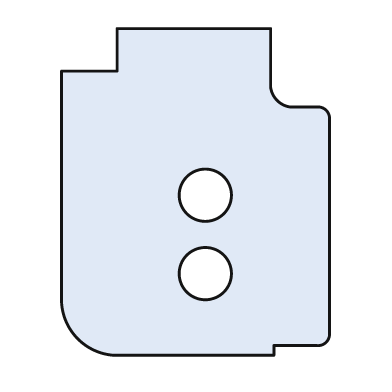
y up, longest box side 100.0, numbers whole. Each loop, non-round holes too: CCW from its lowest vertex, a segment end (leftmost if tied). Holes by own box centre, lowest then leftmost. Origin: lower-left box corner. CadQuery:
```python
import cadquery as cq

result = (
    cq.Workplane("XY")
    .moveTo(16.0, 0.0)
    .lineTo(65.0, 0.0)
    .lineTo(65.0, 3.0)
    .lineTo(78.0, 3.0)
    .threePointArc((81.0, 4.0), (82.0, 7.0))
    .lineTo(82.0, 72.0)
    .threePointArc((81.0, 75.0), (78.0, 76.0))
    .lineTo(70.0, 76.0)
    .threePointArc((66.0, 78.0), (64.0, 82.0))
    .lineTo(64.0, 100.0)
    .lineTo(17.0, 100.0)
    .lineTo(17.0, 87.0)
    .lineTo(0.0, 87.0)
    .lineTo(0.0, 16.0)
    .threePointArc((5.0, 5.0), (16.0, 0.0))
    .close()
    .moveTo(44.0, 25.0)
    .circle(8.0)
    .moveTo(44.0, 49.0)
    .circle(8.0)
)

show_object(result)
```